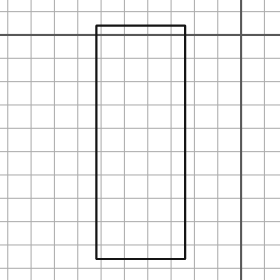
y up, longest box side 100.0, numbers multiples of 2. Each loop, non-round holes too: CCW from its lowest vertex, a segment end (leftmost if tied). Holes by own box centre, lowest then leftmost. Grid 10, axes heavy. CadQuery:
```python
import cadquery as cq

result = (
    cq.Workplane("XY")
    .moveTo(-62.0, -96.0)
    .lineTo(-24.0, -96.0)
    .lineTo(-24.0, 4.0)
    .lineTo(-62.0, 4.0)
    .close()
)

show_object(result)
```